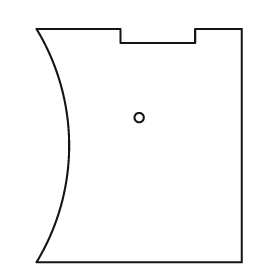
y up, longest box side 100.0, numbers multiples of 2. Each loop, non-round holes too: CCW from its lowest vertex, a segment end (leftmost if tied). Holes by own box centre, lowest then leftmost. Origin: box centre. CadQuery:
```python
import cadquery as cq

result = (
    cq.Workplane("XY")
    .moveTo(-44.0, -50.0)
    .lineTo(44.0, -50.0)
    .lineTo(44.0, 50.0)
    .lineTo(24.0, 50.0)
    .lineTo(24.0, 44.0)
    .lineTo(-8.0, 44.0)
    .lineTo(-8.0, 50.0)
    .lineTo(-44.0, 50.0)
    .threePointArc((-30.0, 0.0), (-44.0, -50.0))
    .close()
    .moveTo(0.0, 12.0)
    .circle(2.0)
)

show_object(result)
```